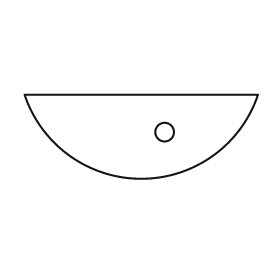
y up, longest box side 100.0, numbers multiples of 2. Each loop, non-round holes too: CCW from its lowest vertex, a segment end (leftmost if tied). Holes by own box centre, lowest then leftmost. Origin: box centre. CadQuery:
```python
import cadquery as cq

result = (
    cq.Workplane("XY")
    .moveTo(-50.0, 18.0)
    .threePointArc((0.0, -18.0), (50.0, 18.0))
    .close()
    .moveTo(10.0, 2.0)
    .circle(4.0)
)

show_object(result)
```